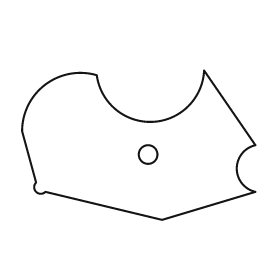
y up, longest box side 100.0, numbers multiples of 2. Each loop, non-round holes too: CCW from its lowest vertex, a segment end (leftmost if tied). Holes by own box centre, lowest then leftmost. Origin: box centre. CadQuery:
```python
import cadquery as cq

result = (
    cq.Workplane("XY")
    .moveTo(10.0, -32.0)
    .lineTo(50.0, -20.0)
    .threePointArc((42.0, -10.0), (50.0, 0.0))
    .lineTo(28.0, 32.0)
    .threePointArc((6.0, 10.0), (-18.0, 30.0))
    .threePointArc((-40.0, 26.0), (-50.0, 6.0))
    .lineTo(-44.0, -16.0)
    .threePointArc((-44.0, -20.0), (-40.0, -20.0))
    .close()
    .moveTo(4.0, -4.0)
    .circle(4.0)
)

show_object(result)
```